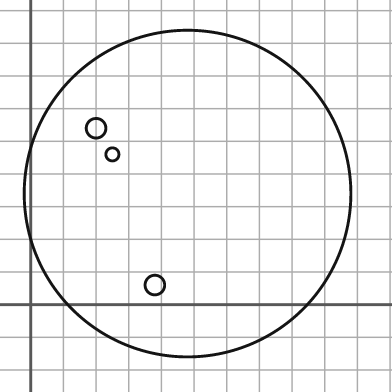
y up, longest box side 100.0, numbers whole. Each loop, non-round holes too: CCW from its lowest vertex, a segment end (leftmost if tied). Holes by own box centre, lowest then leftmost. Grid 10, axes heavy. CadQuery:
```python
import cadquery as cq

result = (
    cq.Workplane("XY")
    .moveTo(48.0, 34.0)
    .circle(50.0)
    .moveTo(38.0, 6.0)
    .circle(3.0)
    .moveTo(25.0, 46.0)
    .circle(2.0)
    .moveTo(20.0, 54.0)
    .circle(3.0)
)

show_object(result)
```